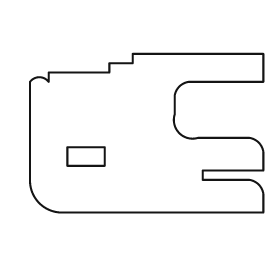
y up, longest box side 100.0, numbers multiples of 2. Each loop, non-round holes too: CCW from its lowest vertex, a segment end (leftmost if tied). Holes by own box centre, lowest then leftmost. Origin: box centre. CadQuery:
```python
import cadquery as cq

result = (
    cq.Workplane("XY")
    .moveTo(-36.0, -34.0)
    .lineTo(50.0, -34.0)
    .lineTo(50.0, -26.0)
    .threePointArc((48.0, -22.0), (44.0, -20.0))
    .lineTo(24.0, -20.0)
    .lineTo(24.0, -16.0)
    .lineTo(50.0, -16.0)
    .lineTo(50.0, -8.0)
    .threePointArc((48.0, -4.0), (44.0, -2.0))
    .lineTo(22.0, -2.0)
    .threePointArc((14.0, 0.0), (12.0, 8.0))
    .lineTo(12.0, 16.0)
    .threePointArc((14.0, 20.0), (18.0, 22.0))
    .lineTo(50.0, 22.0)
    .lineTo(50.0, 34.0)
    .lineTo(-6.0, 34.0)
    .lineTo(-6.0, 30.0)
    .lineTo(-16.0, 30.0)
    .lineTo(-16.0, 26.0)
    .lineTo(-42.0, 26.0)
    .lineTo(-42.0, 22.0)
    .threePointArc((-46.0, 24.0), (-50.0, 22.0))
    .lineTo(-50.0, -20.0)
    .threePointArc((-46.0, -30.0), (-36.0, -34.0))
    .close()
    .moveTo(-34.0, -14.0)
    .lineTo(-18.0, -14.0)
    .lineTo(-18.0, -6.0)
    .lineTo(-34.0, -6.0)
    .close()
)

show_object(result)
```